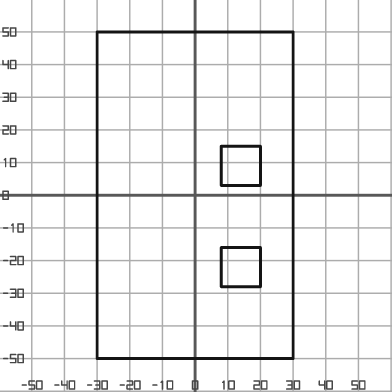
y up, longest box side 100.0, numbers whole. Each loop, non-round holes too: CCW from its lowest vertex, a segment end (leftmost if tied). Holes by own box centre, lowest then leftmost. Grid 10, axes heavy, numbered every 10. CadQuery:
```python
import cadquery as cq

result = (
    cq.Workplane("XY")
    .moveTo(-30.0, -50.0)
    .lineTo(30.0, -50.0)
    .lineTo(30.0, 50.0)
    .lineTo(-30.0, 50.0)
    .close()
    .moveTo(8.0, -28.0)
    .lineTo(20.0, -28.0)
    .lineTo(20.0, -16.0)
    .lineTo(8.0, -16.0)
    .close()
    .moveTo(8.0, 3.0)
    .lineTo(20.0, 3.0)
    .lineTo(20.0, 15.0)
    .lineTo(8.0, 15.0)
    .close()
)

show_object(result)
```